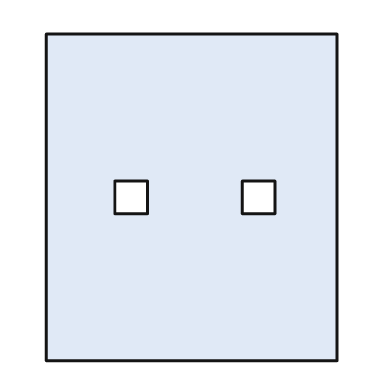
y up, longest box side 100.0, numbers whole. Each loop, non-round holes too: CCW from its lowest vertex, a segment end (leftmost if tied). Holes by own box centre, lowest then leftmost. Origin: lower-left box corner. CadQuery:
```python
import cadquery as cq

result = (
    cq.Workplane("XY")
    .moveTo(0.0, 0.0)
    .lineTo(89.0, 0.0)
    .lineTo(89.0, 100.0)
    .lineTo(0.0, 100.0)
    .close()
    .moveTo(21.0, 45.0)
    .lineTo(31.0, 45.0)
    .lineTo(31.0, 55.0)
    .lineTo(21.0, 55.0)
    .close()
    .moveTo(60.0, 45.0)
    .lineTo(70.0, 45.0)
    .lineTo(70.0, 55.0)
    .lineTo(60.0, 55.0)
    .close()
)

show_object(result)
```